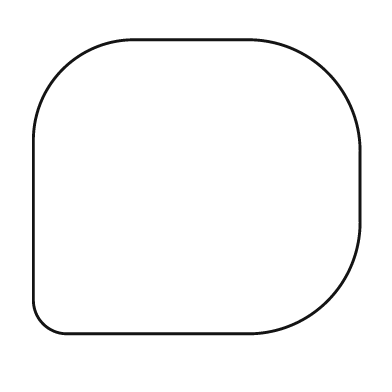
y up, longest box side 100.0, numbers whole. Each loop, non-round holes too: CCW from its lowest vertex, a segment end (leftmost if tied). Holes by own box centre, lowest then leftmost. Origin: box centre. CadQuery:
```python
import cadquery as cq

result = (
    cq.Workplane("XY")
    .moveTo(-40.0, -45.0)
    .lineTo(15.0, -45.0)
    .threePointArc((40.0, -35.0), (50.0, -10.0))
    .lineTo(50.0, 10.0)
    .threePointArc((40.0, 35.0), (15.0, 45.0))
    .lineTo(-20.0, 45.0)
    .threePointArc((-41.0, 36.0), (-50.0, 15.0))
    .lineTo(-50.0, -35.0)
    .threePointArc((-47.0, -42.0), (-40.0, -45.0))
    .close()
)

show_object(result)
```